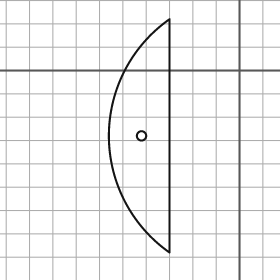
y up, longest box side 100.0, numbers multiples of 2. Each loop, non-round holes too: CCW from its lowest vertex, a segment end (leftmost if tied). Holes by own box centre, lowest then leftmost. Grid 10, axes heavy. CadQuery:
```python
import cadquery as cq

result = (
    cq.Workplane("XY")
    .moveTo(-30.0, -78.0)
    .lineTo(-30.0, 22.0)
    .threePointArc((-56.0, -28.0), (-30.0, -78.0))
    .close()
    .moveTo(-42.0, -28.0)
    .circle(2.0)
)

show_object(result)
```